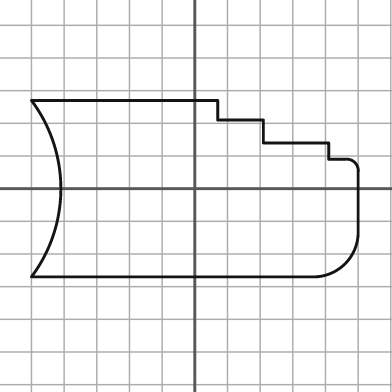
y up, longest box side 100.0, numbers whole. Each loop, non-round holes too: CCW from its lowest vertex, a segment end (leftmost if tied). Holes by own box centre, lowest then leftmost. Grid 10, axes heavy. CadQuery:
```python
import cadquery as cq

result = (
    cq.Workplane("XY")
    .moveTo(-50.0, -27.0)
    .lineTo(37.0, -27.0)
    .threePointArc((46.0, -23.0), (50.0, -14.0))
    .lineTo(50.0, 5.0)
    .threePointArc((49.0, 8.0), (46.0, 9.0))
    .lineTo(41.0, 9.0)
    .lineTo(41.0, 14.0)
    .lineTo(21.0, 14.0)
    .lineTo(21.0, 21.0)
    .lineTo(7.0, 21.0)
    .lineTo(7.0, 27.0)
    .lineTo(-50.0, 27.0)
    .threePointArc((-41.0, 0.0), (-50.0, -27.0))
    .close()
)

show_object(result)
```